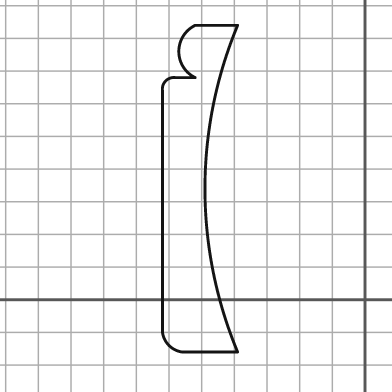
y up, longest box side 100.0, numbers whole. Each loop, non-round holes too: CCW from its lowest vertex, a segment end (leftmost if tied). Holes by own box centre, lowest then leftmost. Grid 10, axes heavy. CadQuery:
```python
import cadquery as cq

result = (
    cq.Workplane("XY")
    .moveTo(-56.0, -16.0)
    .lineTo(-39.0, -16.0)
    .threePointArc((-49.0, 34.0), (-39.0, 84.0))
    .lineTo(-52.0, 84.0)
    .threePointArc((-57.0, 76.0), (-52.0, 68.0))
    .lineTo(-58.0, 68.0)
    .threePointArc((-61.0, 67.0), (-62.0, 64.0))
    .lineTo(-62.0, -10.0)
    .threePointArc((-60.0, -14.0), (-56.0, -16.0))
    .close()
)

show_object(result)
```